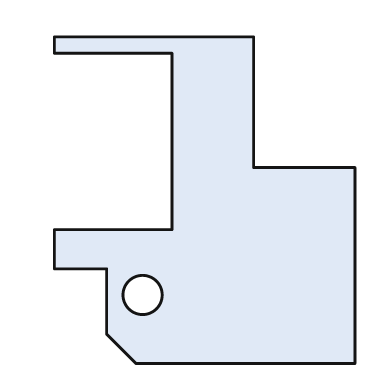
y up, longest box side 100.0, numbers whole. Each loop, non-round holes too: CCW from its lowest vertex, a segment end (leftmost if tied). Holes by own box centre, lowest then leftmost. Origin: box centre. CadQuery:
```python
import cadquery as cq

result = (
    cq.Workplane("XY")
    .moveTo(-21.0, -50.0)
    .lineTo(46.0, -50.0)
    .lineTo(46.0, 10.0)
    .lineTo(15.0, 10.0)
    .lineTo(15.0, 50.0)
    .lineTo(-46.0, 50.0)
    .lineTo(-46.0, 45.0)
    .lineTo(-10.0, 45.0)
    .lineTo(-10.0, -9.0)
    .lineTo(-46.0, -9.0)
    .lineTo(-46.0, -21.0)
    .lineTo(-30.0, -21.0)
    .lineTo(-30.0, -41.0)
    .close()
    .moveTo(-19.0, -29.0)
    .circle(6.0)
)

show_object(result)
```